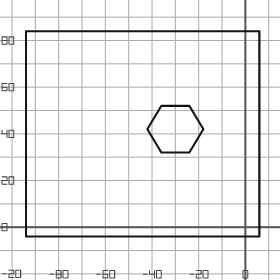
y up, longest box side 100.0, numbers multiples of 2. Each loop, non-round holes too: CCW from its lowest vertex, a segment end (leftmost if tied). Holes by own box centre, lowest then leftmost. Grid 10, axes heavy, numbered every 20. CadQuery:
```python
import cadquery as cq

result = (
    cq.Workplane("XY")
    .moveTo(-94.0, -4.0)
    .lineTo(6.0, -4.0)
    .lineTo(6.0, 84.0)
    .lineTo(-94.0, 84.0)
    .close()
    .moveTo(-36.0, 32.0)
    .lineTo(-24.0, 32.0)
    .lineTo(-18.0, 42.0)
    .lineTo(-24.0, 52.0)
    .lineTo(-36.0, 52.0)
    .lineTo(-42.0, 42.0)
    .close()
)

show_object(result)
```